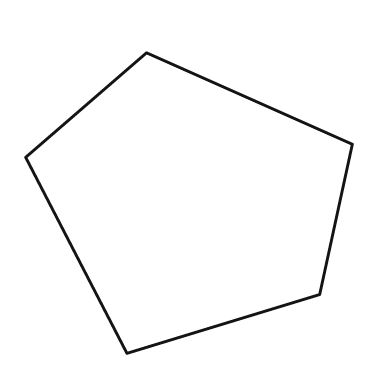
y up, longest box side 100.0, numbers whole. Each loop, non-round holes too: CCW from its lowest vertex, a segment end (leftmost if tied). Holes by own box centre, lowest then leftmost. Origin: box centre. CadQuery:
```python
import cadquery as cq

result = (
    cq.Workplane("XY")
    .moveTo(-19.0, -46.0)
    .lineTo(40.0, -28.0)
    .lineTo(50.0, 18.0)
    .lineTo(-13.0, 46.0)
    .lineTo(-50.0, 14.0)
    .close()
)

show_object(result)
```